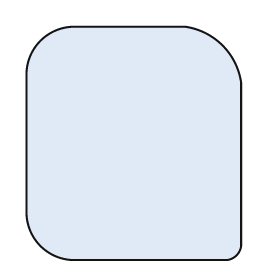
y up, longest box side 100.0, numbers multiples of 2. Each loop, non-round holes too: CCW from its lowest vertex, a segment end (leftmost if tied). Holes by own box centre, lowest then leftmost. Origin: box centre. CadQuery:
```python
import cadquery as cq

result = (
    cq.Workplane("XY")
    .moveTo(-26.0, -50.0)
    .lineTo(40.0, -50.0)
    .threePointArc((44.0, -48.0), (46.0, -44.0))
    .lineTo(46.0, 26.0)
    .threePointArc((38.0, 42.0), (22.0, 50.0))
    .lineTo(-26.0, 50.0)
    .threePointArc((-40.0, 44.0), (-46.0, 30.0))
    .lineTo(-46.0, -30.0)
    .threePointArc((-40.0, -44.0), (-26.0, -50.0))
    .close()
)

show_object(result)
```